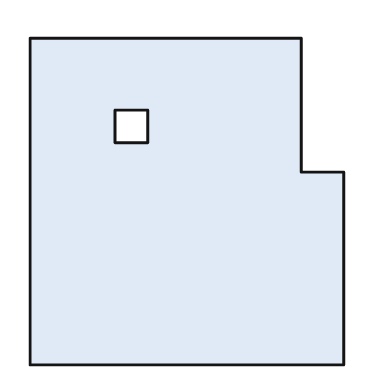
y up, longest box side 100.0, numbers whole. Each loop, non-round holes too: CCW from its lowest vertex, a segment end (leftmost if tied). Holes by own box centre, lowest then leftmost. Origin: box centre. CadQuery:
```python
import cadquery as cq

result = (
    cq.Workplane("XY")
    .moveTo(-48.0, -50.0)
    .lineTo(48.0, -50.0)
    .lineTo(48.0, 9.0)
    .lineTo(35.0, 9.0)
    .lineTo(35.0, 50.0)
    .lineTo(-48.0, 50.0)
    .close()
    .moveTo(-22.0, 18.0)
    .lineTo(-12.0, 18.0)
    .lineTo(-12.0, 28.0)
    .lineTo(-22.0, 28.0)
    .close()
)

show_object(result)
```